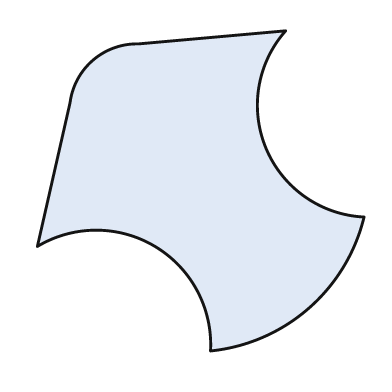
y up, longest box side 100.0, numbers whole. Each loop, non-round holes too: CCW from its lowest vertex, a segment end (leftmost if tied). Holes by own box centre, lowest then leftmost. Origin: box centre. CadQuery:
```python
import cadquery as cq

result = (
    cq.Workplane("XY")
    .moveTo(3.0, -49.0)
    .threePointArc((33.0, -36.0), (50.0, -8.0))
    .threePointArc((20.0, 13.0), (26.0, 49.0))
    .lineTo(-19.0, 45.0)
    .threePointArc((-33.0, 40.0), (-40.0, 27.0))
    .lineTo(-50.0, -17.0)
    .threePointArc((-14.0, -17.0), (3.0, -49.0))
    .close()
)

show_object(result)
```